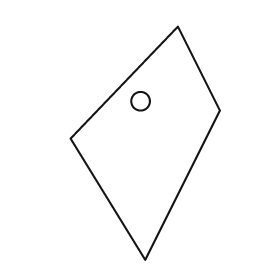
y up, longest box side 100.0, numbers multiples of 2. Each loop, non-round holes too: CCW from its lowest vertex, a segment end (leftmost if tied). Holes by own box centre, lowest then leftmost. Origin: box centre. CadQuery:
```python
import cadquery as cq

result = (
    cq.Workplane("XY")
    .moveTo(0.0, -50.0)
    .lineTo(32.0, 14.0)
    .lineTo(14.0, 50.0)
    .lineTo(-32.0, 2.0)
    .close()
    .moveTo(-2.0, 18.0)
    .circle(4.0)
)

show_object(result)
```